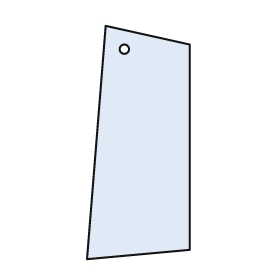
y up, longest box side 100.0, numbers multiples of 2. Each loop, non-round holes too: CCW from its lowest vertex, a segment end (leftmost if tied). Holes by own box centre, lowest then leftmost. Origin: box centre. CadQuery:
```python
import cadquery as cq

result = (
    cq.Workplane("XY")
    .moveTo(-22.0, -50.0)
    .lineTo(22.0, -46.0)
    .lineTo(22.0, 42.0)
    .lineTo(-14.0, 50.0)
    .close()
    .moveTo(-6.0, 40.0)
    .circle(2.0)
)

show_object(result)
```